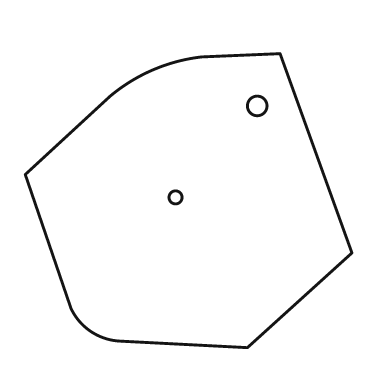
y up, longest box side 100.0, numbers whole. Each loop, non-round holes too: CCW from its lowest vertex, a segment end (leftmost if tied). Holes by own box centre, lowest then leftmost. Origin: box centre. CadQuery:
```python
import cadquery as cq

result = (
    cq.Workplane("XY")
    .moveTo(18.0, -45.0)
    .lineTo(50.0, -16.0)
    .lineTo(28.0, 45.0)
    .lineTo(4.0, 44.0)
    .threePointArc((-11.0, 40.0), (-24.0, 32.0))
    .lineTo(-50.0, 8.0)
    .lineTo(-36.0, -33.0)
    .threePointArc((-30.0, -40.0), (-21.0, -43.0))
    .close()
    .moveTo(-4.0, 1.0)
    .circle(2.0)
    .moveTo(21.0, 29.0)
    .circle(3.0)
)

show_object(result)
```